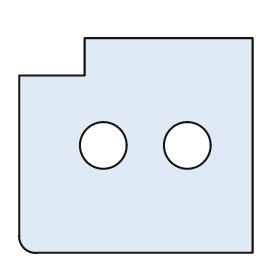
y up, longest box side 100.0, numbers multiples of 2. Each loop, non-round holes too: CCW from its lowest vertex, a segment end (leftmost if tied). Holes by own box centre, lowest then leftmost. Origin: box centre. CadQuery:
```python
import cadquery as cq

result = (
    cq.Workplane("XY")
    .moveTo(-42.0, -46.0)
    .lineTo(50.0, -46.0)
    .lineTo(50.0, 46.0)
    .lineTo(-22.0, 46.0)
    .lineTo(-22.0, 30.0)
    .lineTo(-50.0, 30.0)
    .lineTo(-50.0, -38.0)
    .threePointArc((-48.0, -44.0), (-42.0, -46.0))
    .close()
    .moveTo(-14.0, 0.0)
    .circle(10.0)
    .moveTo(22.0, 0.0)
    .circle(10.0)
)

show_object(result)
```